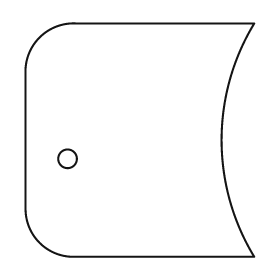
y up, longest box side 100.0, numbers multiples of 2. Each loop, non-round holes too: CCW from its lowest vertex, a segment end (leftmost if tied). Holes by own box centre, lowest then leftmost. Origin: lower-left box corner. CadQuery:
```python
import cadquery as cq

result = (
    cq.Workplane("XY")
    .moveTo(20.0, 0.0)
    .lineTo(98.0, 0.0)
    .threePointArc((84.0, 50.0), (98.0, 100.0))
    .lineTo(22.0, 100.0)
    .threePointArc((6.0, 94.0), (0.0, 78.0))
    .lineTo(0.0, 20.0)
    .threePointArc((6.0, 6.0), (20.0, 0.0))
    .close()
    .moveTo(18.0, 42.0)
    .circle(4.0)
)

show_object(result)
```